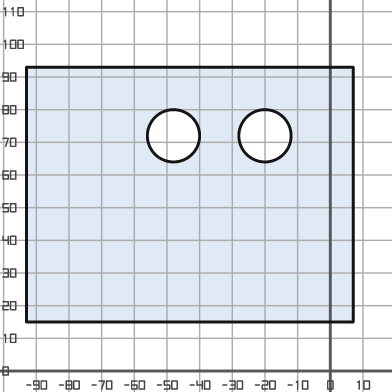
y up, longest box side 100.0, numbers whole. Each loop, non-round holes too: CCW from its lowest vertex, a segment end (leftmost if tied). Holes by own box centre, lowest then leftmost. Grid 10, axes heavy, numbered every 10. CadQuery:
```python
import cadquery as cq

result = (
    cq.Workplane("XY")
    .moveTo(-93.0, 15.0)
    .lineTo(7.0, 15.0)
    .lineTo(7.0, 93.0)
    .lineTo(-93.0, 93.0)
    .close()
    .moveTo(-48.0, 72.0)
    .circle(8.0)
    .moveTo(-20.0, 72.0)
    .circle(8.0)
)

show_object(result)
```